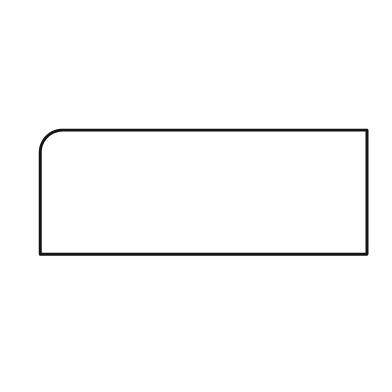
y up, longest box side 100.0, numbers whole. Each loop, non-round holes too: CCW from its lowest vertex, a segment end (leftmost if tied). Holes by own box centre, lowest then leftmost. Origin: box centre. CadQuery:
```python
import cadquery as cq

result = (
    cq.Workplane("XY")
    .moveTo(-50.0, -19.0)
    .lineTo(50.0, -19.0)
    .lineTo(50.0, 19.0)
    .lineTo(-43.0, 19.0)
    .threePointArc((-48.0, 17.0), (-50.0, 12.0))
    .close()
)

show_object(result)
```